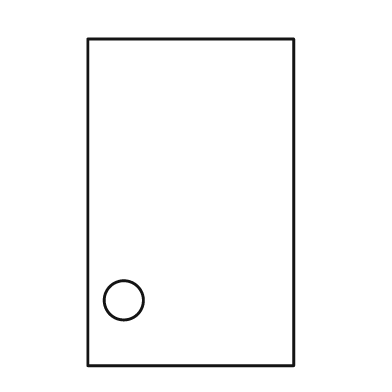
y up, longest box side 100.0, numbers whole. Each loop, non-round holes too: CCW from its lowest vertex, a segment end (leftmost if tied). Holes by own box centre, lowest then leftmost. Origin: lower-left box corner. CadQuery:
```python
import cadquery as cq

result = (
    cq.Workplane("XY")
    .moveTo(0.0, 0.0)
    .lineTo(63.0, 0.0)
    .lineTo(63.0, 100.0)
    .lineTo(0.0, 100.0)
    .close()
    .moveTo(11.0, 20.0)
    .circle(6.0)
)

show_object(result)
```